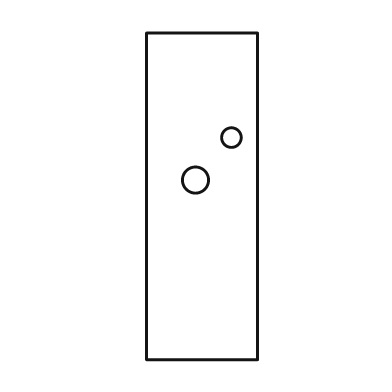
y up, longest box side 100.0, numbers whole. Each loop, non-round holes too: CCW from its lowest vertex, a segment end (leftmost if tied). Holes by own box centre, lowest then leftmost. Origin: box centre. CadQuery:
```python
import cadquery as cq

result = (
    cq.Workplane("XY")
    .moveTo(-17.0, -50.0)
    .lineTo(17.0, -50.0)
    .lineTo(17.0, 50.0)
    .lineTo(-17.0, 50.0)
    .close()
    .moveTo(-2.0, 5.0)
    .circle(4.0)
    .moveTo(9.0, 18.0)
    .circle(3.0)
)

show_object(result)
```